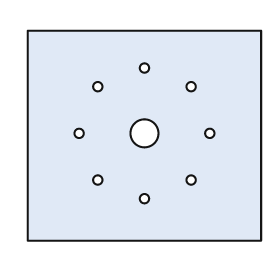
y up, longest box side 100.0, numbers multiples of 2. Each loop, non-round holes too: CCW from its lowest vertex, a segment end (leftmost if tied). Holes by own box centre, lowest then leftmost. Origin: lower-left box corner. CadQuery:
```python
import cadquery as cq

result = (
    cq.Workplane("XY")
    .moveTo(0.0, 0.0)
    .lineTo(100.0, 0.0)
    .lineTo(100.0, 90.0)
    .lineTo(0.0, 90.0)
    .close()
    .moveTo(50.0, 18.0)
    .circle(2.0)
    .moveTo(30.0, 26.0)
    .circle(2.0)
    .moveTo(70.0, 26.0)
    .circle(2.0)
    .moveTo(22.0, 46.0)
    .circle(2.0)
    .moveTo(50.0, 46.0)
    .circle(6.0)
    .moveTo(78.0, 46.0)
    .circle(2.0)
    .moveTo(30.0, 66.0)
    .circle(2.0)
    .moveTo(70.0, 66.0)
    .circle(2.0)
    .moveTo(50.0, 74.0)
    .circle(2.0)
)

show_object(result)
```